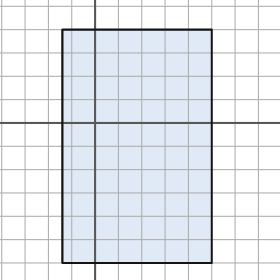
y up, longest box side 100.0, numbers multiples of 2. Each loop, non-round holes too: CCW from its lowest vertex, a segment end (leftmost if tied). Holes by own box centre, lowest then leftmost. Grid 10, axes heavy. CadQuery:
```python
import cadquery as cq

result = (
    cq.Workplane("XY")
    .moveTo(-14.0, -60.0)
    .lineTo(50.0, -60.0)
    .lineTo(50.0, 40.0)
    .lineTo(-14.0, 40.0)
    .close()
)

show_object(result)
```